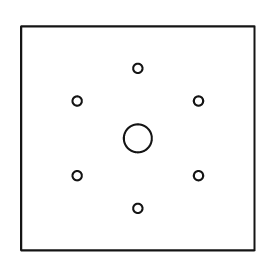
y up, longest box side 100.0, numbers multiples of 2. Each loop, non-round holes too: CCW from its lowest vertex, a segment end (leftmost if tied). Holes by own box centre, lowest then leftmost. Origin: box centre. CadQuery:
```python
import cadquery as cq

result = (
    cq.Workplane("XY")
    .moveTo(-50.0, -48.0)
    .lineTo(50.0, -48.0)
    .lineTo(50.0, 48.0)
    .lineTo(-50.0, 48.0)
    .close()
    .moveTo(0.0, -30.0)
    .circle(2.0)
    .moveTo(-26.0, -16.0)
    .circle(2.0)
    .moveTo(26.0, -16.0)
    .circle(2.0)
    .moveTo(0.0, 0.0)
    .circle(6.0)
    .moveTo(-26.0, 16.0)
    .circle(2.0)
    .moveTo(26.0, 16.0)
    .circle(2.0)
    .moveTo(0.0, 30.0)
    .circle(2.0)
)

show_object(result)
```